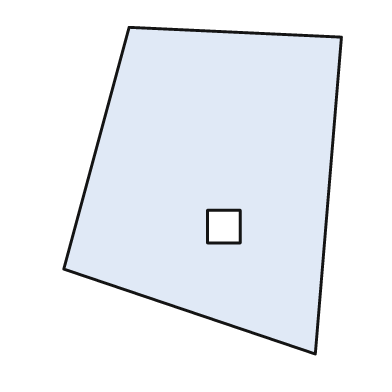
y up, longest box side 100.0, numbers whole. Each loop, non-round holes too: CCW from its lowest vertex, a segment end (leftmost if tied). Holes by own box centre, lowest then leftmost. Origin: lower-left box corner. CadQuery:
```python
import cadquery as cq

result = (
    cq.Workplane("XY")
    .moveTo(77.0, 0.0)
    .lineTo(85.0, 97.0)
    .lineTo(20.0, 100.0)
    .lineTo(0.0, 26.0)
    .close()
    .moveTo(44.0, 34.0)
    .lineTo(54.0, 34.0)
    .lineTo(54.0, 44.0)
    .lineTo(44.0, 44.0)
    .close()
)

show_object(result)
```